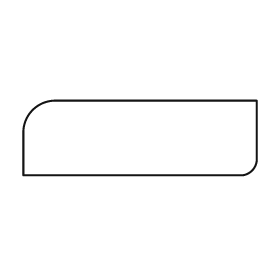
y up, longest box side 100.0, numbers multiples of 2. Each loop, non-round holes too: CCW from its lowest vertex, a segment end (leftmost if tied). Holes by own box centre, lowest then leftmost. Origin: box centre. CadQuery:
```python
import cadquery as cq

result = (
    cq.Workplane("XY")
    .moveTo(-50.0, -16.0)
    .lineTo(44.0, -16.0)
    .threePointArc((48.0, -14.0), (50.0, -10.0))
    .lineTo(50.0, 16.0)
    .lineTo(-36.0, 16.0)
    .threePointArc((-46.0, 12.0), (-50.0, 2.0))
    .close()
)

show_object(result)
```